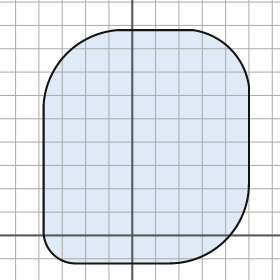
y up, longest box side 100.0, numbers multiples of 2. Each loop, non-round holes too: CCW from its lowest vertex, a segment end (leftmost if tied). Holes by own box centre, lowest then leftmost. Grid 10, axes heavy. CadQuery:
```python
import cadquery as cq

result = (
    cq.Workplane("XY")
    .moveTo(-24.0, -12.0)
    .lineTo(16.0, -12.0)
    .threePointArc((40.0, -2.0), (50.0, 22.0))
    .lineTo(50.0, 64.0)
    .threePointArc((42.0, 80.0), (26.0, 88.0))
    .lineTo(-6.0, 88.0)
    .threePointArc((-28.0, 78.0), (-38.0, 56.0))
    .lineTo(-38.0, 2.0)
    .threePointArc((-34.0, -8.0), (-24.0, -12.0))
    .close()
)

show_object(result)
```